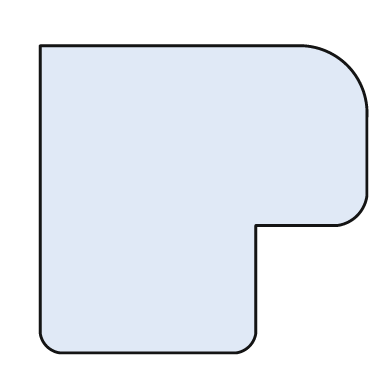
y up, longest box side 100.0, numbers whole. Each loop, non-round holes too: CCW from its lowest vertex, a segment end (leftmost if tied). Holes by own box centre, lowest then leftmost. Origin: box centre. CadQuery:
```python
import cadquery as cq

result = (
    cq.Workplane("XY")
    .moveTo(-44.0, -47.0)
    .lineTo(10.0, -47.0)
    .threePointArc((14.0, -45.0), (16.0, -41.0))
    .lineTo(16.0, -8.0)
    .lineTo(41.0, -8.0)
    .threePointArc((47.0, -5.0), (50.0, 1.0))
    .lineTo(50.0, 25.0)
    .threePointArc((44.0, 41.0), (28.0, 47.0))
    .lineTo(-50.0, 47.0)
    .lineTo(-50.0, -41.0)
    .threePointArc((-48.0, -45.0), (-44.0, -47.0))
    .close()
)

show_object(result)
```